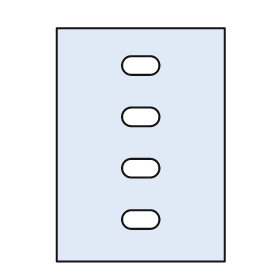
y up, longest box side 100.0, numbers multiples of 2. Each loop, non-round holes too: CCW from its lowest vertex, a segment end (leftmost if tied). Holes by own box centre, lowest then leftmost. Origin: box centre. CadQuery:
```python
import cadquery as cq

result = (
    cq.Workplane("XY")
    .moveTo(-36.0, -50.0)
    .lineTo(36.0, -50.0)
    .lineTo(36.0, 50.0)
    .lineTo(-36.0, 50.0)
    .close()
    .moveTo(-4.0, -36.0)
    .lineTo(4.0, -36.0)
    .threePointArc((8.0, -32.0), (4.0, -28.0))
    .lineTo(-4.0, -28.0)
    .threePointArc((-8.0, -32.0), (-4.0, -36.0))
    .close()
    .moveTo(-4.0, -14.0)
    .lineTo(4.0, -14.0)
    .threePointArc((8.0, -10.0), (4.0, -6.0))
    .lineTo(-4.0, -6.0)
    .threePointArc((-8.0, -10.0), (-4.0, -14.0))
    .close()
    .moveTo(-4.0, 8.0)
    .lineTo(4.0, 8.0)
    .threePointArc((8.0, 12.0), (4.0, 16.0))
    .lineTo(-4.0, 16.0)
    .threePointArc((-8.0, 12.0), (-4.0, 8.0))
    .close()
    .moveTo(-4.0, 30.0)
    .lineTo(4.0, 30.0)
    .threePointArc((8.0, 34.0), (4.0, 38.0))
    .lineTo(-4.0, 38.0)
    .threePointArc((-8.0, 34.0), (-4.0, 30.0))
    .close()
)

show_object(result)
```